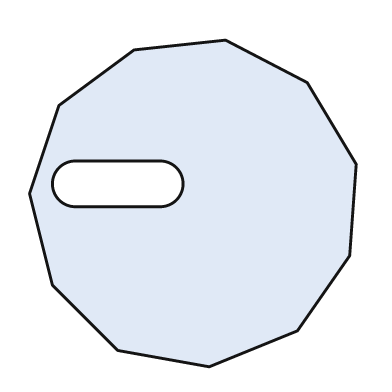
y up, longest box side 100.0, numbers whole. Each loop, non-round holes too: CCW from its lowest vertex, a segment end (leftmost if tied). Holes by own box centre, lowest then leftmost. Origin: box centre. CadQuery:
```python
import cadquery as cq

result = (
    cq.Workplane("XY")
    .moveTo(5.0, -50.0)
    .lineTo(32.0, -39.0)
    .lineTo(48.0, -16.0)
    .lineTo(50.0, 12.0)
    .lineTo(35.0, 37.0)
    .lineTo(10.0, 50.0)
    .lineTo(-18.0, 47.0)
    .lineTo(-41.0, 30.0)
    .lineTo(-50.0, 3.0)
    .lineTo(-43.0, -25.0)
    .lineTo(-23.0, -45.0)
    .close()
    .moveTo(-36.0, -1.0)
    .lineTo(-10.0, -1.0)
    .threePointArc((-3.0, 6.0), (-10.0, 13.0))
    .lineTo(-36.0, 13.0)
    .threePointArc((-43.0, 6.0), (-36.0, -1.0))
    .close()
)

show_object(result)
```